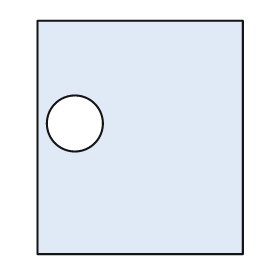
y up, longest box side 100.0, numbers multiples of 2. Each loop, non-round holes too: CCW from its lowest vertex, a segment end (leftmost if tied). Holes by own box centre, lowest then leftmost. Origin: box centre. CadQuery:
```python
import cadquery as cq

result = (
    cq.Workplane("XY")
    .moveTo(-44.0, -50.0)
    .lineTo(44.0, -50.0)
    .lineTo(44.0, 50.0)
    .lineTo(-44.0, 50.0)
    .close()
    .moveTo(-28.0, 6.0)
    .circle(12.0)
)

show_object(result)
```